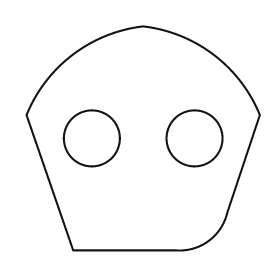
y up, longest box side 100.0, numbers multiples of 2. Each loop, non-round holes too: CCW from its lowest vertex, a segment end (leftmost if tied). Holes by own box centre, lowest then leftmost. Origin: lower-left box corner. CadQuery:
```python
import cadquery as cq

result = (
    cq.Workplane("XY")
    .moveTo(20.0, 0.0)
    .lineTo(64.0, 0.0)
    .threePointArc((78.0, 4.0), (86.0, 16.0))
    .lineTo(100.0, 58.0)
    .threePointArc((80.0, 84.0), (50.0, 96.0))
    .threePointArc((20.0, 84.0), (0.0, 58.0))
    .close()
    .moveTo(28.0, 48.0)
    .circle(12.0)
    .moveTo(72.0, 48.0)
    .circle(12.0)
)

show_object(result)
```